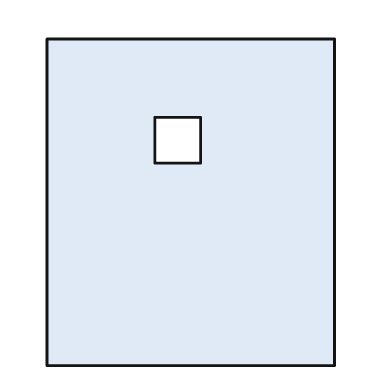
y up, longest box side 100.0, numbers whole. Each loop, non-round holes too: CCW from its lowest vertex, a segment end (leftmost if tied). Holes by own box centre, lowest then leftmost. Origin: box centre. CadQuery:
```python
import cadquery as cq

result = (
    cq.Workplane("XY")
    .moveTo(-44.0, -50.0)
    .lineTo(44.0, -50.0)
    .lineTo(44.0, 50.0)
    .lineTo(-44.0, 50.0)
    .close()
    .moveTo(-11.0, 12.0)
    .lineTo(3.0, 12.0)
    .lineTo(3.0, 26.0)
    .lineTo(-11.0, 26.0)
    .close()
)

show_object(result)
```